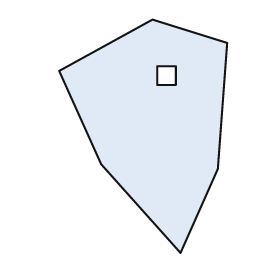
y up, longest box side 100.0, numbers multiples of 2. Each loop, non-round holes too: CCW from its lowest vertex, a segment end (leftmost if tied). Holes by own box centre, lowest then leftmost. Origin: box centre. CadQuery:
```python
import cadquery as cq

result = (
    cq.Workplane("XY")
    .moveTo(16.0, -50.0)
    .lineTo(32.0, -14.0)
    .lineTo(36.0, 40.0)
    .lineTo(4.0, 50.0)
    .lineTo(-36.0, 28.0)
    .lineTo(-18.0, -12.0)
    .close()
    .moveTo(6.0, 22.0)
    .lineTo(14.0, 22.0)
    .lineTo(14.0, 30.0)
    .lineTo(6.0, 30.0)
    .close()
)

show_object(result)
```